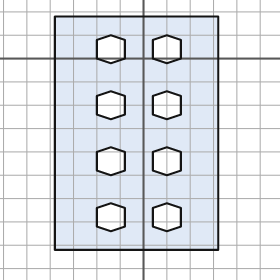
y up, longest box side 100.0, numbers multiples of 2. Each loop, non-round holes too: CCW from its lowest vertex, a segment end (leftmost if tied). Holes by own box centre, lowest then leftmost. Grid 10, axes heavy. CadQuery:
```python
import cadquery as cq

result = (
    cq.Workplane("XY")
    .moveTo(-38.0, -82.0)
    .lineTo(32.0, -82.0)
    .lineTo(32.0, 18.0)
    .lineTo(-38.0, 18.0)
    .close()
    .moveTo(-14.0, -74.0)
    .lineTo(-8.0, -72.0)
    .lineTo(-8.0, -64.0)
    .lineTo(-14.0, -62.0)
    .lineTo(-20.0, -64.0)
    .lineTo(-20.0, -72.0)
    .close()
    .moveTo(10.0, -74.0)
    .lineTo(16.0, -72.0)
    .lineTo(16.0, -64.0)
    .lineTo(10.0, -62.0)
    .lineTo(4.0, -64.0)
    .lineTo(4.0, -72.0)
    .close()
    .moveTo(-14.0, -50.0)
    .lineTo(-8.0, -48.0)
    .lineTo(-8.0, -40.0)
    .lineTo(-14.0, -38.0)
    .lineTo(-20.0, -40.0)
    .lineTo(-20.0, -48.0)
    .close()
    .moveTo(10.0, -50.0)
    .lineTo(16.0, -48.0)
    .lineTo(16.0, -40.0)
    .lineTo(10.0, -38.0)
    .lineTo(4.0, -40.0)
    .lineTo(4.0, -48.0)
    .close()
    .moveTo(-14.0, -26.0)
    .lineTo(-8.0, -24.0)
    .lineTo(-8.0, -16.0)
    .lineTo(-14.0, -14.0)
    .lineTo(-20.0, -16.0)
    .lineTo(-20.0, -24.0)
    .close()
    .moveTo(10.0, -26.0)
    .lineTo(16.0, -24.0)
    .lineTo(16.0, -16.0)
    .lineTo(10.0, -14.0)
    .lineTo(4.0, -16.0)
    .lineTo(4.0, -24.0)
    .close()
    .moveTo(-14.0, -2.0)
    .lineTo(-8.0, 0.0)
    .lineTo(-8.0, 8.0)
    .lineTo(-14.0, 10.0)
    .lineTo(-20.0, 8.0)
    .lineTo(-20.0, 0.0)
    .close()
    .moveTo(10.0, -2.0)
    .lineTo(16.0, 0.0)
    .lineTo(16.0, 8.0)
    .lineTo(10.0, 10.0)
    .lineTo(4.0, 8.0)
    .lineTo(4.0, 0.0)
    .close()
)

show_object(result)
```